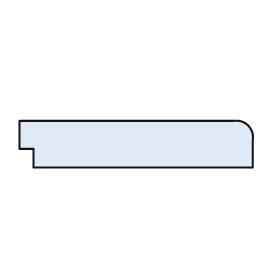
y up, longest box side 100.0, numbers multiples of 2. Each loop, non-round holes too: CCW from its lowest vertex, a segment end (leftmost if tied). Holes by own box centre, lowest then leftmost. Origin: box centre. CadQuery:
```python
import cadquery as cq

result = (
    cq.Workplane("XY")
    .moveTo(-44.0, -10.0)
    .lineTo(50.0, -10.0)
    .lineTo(50.0, 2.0)
    .threePointArc((48.0, 8.0), (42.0, 10.0))
    .lineTo(-50.0, 10.0)
    .lineTo(-50.0, -2.0)
    .lineTo(-44.0, -2.0)
    .close()
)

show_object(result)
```